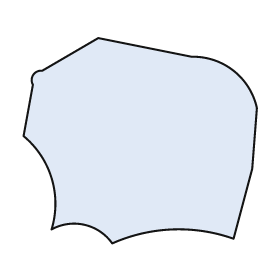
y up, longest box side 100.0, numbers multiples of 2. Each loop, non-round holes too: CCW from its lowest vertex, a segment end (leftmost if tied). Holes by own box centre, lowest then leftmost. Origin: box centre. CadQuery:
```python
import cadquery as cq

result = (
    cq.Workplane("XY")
    .moveTo(-12.0, -44.0)
    .threePointArc((14.0, -38.0), (40.0, -42.0))
    .lineTo(48.0, -12.0)
    .lineTo(50.0, 14.0)
    .threePointArc((40.0, 30.0), (22.0, 36.0))
    .lineTo(-18.0, 44.0)
    .lineTo(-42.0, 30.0)
    .threePointArc((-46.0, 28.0), (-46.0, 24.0))
    .lineTo(-50.0, 2.0)
    .threePointArc((-38.0, -16.0), (-38.0, -38.0))
    .threePointArc((-24.0, -36.0), (-12.0, -44.0))
    .close()
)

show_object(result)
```